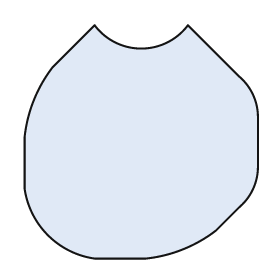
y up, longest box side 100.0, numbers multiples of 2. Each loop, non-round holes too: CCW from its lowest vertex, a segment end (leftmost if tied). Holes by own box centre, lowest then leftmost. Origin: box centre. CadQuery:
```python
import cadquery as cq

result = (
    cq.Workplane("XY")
    .moveTo(-20.0, -50.0)
    .lineTo(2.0, -50.0)
    .threePointArc((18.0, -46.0), (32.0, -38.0))
    .lineTo(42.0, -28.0)
    .threePointArc((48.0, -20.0), (50.0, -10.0))
    .lineTo(50.0, 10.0)
    .threePointArc((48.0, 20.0), (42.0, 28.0))
    .lineTo(20.0, 50.0)
    .threePointArc((0.0, 40.0), (-20.0, 50.0))
    .lineTo(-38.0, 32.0)
    .threePointArc((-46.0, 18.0), (-50.0, 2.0))
    .lineTo(-50.0, -20.0)
    .threePointArc((-40.0, -40.0), (-20.0, -50.0))
    .close()
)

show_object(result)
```